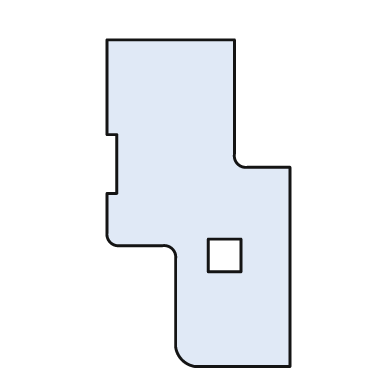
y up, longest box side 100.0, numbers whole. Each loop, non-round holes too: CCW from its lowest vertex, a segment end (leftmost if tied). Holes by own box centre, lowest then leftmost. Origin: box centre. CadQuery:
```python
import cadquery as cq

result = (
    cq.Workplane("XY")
    .moveTo(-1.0, -50.0)
    .lineTo(28.0, -50.0)
    .lineTo(28.0, 11.0)
    .lineTo(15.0, 11.0)
    .threePointArc((12.0, 12.0), (11.0, 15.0))
    .lineTo(11.0, 50.0)
    .lineTo(-28.0, 50.0)
    .lineTo(-28.0, 21.0)
    .lineTo(-25.0, 21.0)
    .lineTo(-25.0, 3.0)
    .lineTo(-28.0, 3.0)
    .lineTo(-28.0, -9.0)
    .threePointArc((-27.0, -12.0), (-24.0, -13.0))
    .lineTo(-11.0, -13.0)
    .threePointArc((-8.0, -14.0), (-7.0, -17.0))
    .lineTo(-7.0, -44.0)
    .threePointArc((-5.0, -48.0), (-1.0, -50.0))
    .close()
    .moveTo(3.0, -21.0)
    .lineTo(13.0, -21.0)
    .lineTo(13.0, -11.0)
    .lineTo(3.0, -11.0)
    .close()
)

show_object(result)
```